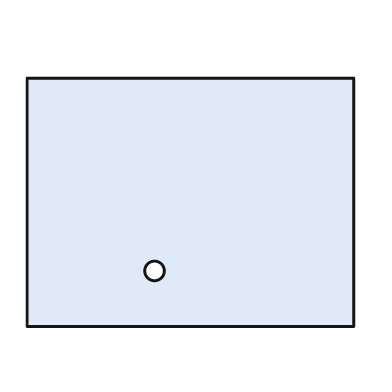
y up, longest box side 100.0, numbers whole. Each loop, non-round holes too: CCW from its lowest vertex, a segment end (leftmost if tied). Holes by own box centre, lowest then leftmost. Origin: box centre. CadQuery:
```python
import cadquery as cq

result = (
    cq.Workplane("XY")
    .moveTo(-50.0, -38.0)
    .lineTo(50.0, -38.0)
    .lineTo(50.0, 38.0)
    .lineTo(-50.0, 38.0)
    .close()
    .moveTo(-11.0, -21.0)
    .circle(3.0)
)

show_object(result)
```